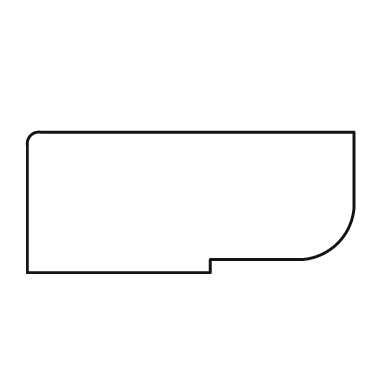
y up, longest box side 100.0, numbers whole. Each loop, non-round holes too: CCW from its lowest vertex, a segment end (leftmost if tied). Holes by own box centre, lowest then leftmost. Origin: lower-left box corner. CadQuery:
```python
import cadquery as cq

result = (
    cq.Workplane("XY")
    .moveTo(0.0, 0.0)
    .lineTo(56.0, 0.0)
    .lineTo(56.0, 4.0)
    .lineTo(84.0, 4.0)
    .threePointArc((95.0, 9.0), (100.0, 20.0))
    .lineTo(100.0, 43.0)
    .lineTo(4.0, 43.0)
    .threePointArc((1.0, 42.0), (0.0, 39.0))
    .close()
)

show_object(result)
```